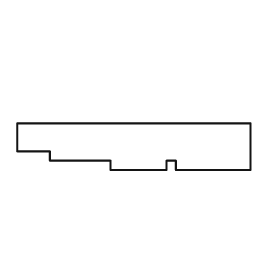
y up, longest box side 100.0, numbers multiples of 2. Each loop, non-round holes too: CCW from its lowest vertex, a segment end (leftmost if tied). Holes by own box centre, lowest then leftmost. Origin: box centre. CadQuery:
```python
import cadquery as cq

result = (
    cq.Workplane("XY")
    .moveTo(-10.0, -10.0)
    .lineTo(14.0, -10.0)
    .lineTo(14.0, -6.0)
    .lineTo(18.0, -6.0)
    .lineTo(18.0, -10.0)
    .lineTo(50.0, -10.0)
    .lineTo(50.0, 10.0)
    .lineTo(-50.0, 10.0)
    .lineTo(-50.0, -2.0)
    .lineTo(-36.0, -2.0)
    .lineTo(-36.0, -6.0)
    .lineTo(-10.0, -6.0)
    .close()
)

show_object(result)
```